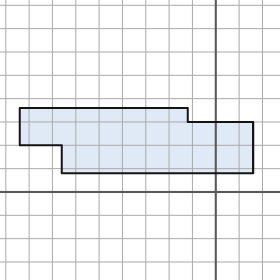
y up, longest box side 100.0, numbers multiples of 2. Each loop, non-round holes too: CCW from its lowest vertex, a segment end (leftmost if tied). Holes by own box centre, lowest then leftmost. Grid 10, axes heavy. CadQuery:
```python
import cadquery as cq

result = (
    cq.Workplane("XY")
    .moveTo(-66.0, 8.0)
    .lineTo(16.0, 8.0)
    .lineTo(16.0, 30.0)
    .lineTo(-12.0, 30.0)
    .lineTo(-12.0, 36.0)
    .lineTo(-84.0, 36.0)
    .lineTo(-84.0, 20.0)
    .lineTo(-66.0, 20.0)
    .close()
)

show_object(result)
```